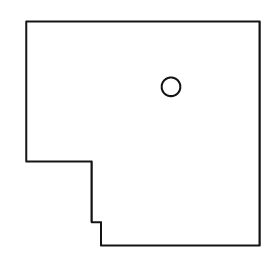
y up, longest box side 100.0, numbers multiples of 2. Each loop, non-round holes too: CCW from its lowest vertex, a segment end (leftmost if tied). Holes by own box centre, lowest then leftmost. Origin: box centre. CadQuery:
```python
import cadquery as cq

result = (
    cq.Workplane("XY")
    .moveTo(-18.0, -48.0)
    .lineTo(50.0, -48.0)
    .lineTo(50.0, 48.0)
    .lineTo(-50.0, 48.0)
    .lineTo(-50.0, -12.0)
    .lineTo(-22.0, -12.0)
    .lineTo(-22.0, -38.0)
    .lineTo(-18.0, -38.0)
    .close()
    .moveTo(12.0, 20.0)
    .circle(4.0)
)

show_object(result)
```